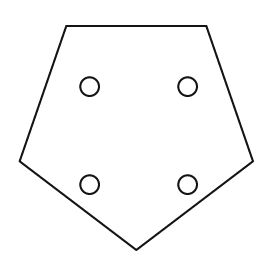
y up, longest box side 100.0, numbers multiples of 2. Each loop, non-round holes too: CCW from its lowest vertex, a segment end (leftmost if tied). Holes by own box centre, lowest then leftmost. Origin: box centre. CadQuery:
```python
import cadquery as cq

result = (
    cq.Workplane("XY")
    .moveTo(0.0, -48.0)
    .lineTo(50.0, -10.0)
    .lineTo(30.0, 48.0)
    .lineTo(-30.0, 48.0)
    .lineTo(-50.0, -10.0)
    .close()
    .moveTo(-20.0, -20.0)
    .circle(4.0)
    .moveTo(22.0, -20.0)
    .circle(4.0)
    .moveTo(-20.0, 22.0)
    .circle(4.0)
    .moveTo(22.0, 22.0)
    .circle(4.0)
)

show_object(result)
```